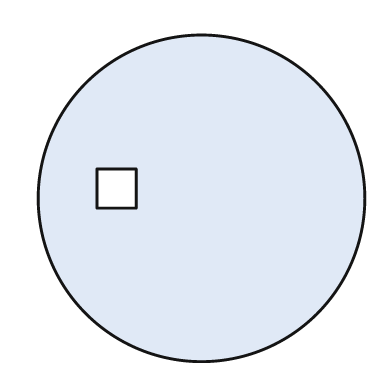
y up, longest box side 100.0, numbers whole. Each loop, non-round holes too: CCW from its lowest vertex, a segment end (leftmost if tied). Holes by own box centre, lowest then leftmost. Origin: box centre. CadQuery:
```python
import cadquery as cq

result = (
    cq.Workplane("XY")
    .moveTo(0.0, 0.0)
    .circle(50.0)
    .moveTo(-32.0, -3.0)
    .lineTo(-20.0, -3.0)
    .lineTo(-20.0, 9.0)
    .lineTo(-32.0, 9.0)
    .close()
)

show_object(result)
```